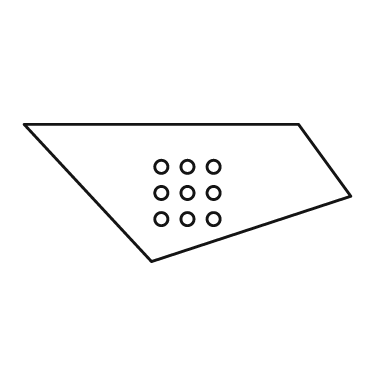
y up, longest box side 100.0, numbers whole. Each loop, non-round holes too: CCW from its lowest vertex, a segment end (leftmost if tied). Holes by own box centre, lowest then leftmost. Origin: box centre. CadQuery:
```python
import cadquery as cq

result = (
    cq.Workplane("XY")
    .moveTo(-11.0, -21.0)
    .lineTo(50.0, -1.0)
    .lineTo(34.0, 21.0)
    .lineTo(-50.0, 21.0)
    .close()
    .moveTo(-8.0, -8.0)
    .circle(2.0)
    .moveTo(0.0, -8.0)
    .circle(2.0)
    .moveTo(8.0, -8.0)
    .circle(2.0)
    .moveTo(-8.0, 0.0)
    .circle(2.0)
    .moveTo(0.0, 0.0)
    .circle(2.0)
    .moveTo(8.0, 0.0)
    .circle(2.0)
    .moveTo(-8.0, 8.0)
    .circle(2.0)
    .moveTo(0.0, 8.0)
    .circle(2.0)
    .moveTo(8.0, 8.0)
    .circle(2.0)
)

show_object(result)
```